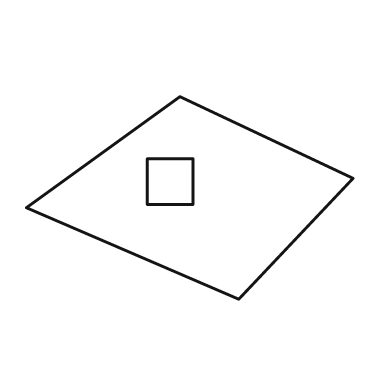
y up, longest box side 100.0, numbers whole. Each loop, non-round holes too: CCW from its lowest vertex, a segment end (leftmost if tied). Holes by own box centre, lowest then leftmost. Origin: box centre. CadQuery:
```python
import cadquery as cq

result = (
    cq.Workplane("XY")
    .moveTo(15.0, -31.0)
    .lineTo(50.0, 6.0)
    .lineTo(-3.0, 31.0)
    .lineTo(-50.0, -3.0)
    .close()
    .moveTo(-13.0, -2.0)
    .lineTo(1.0, -2.0)
    .lineTo(1.0, 12.0)
    .lineTo(-13.0, 12.0)
    .close()
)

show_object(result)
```